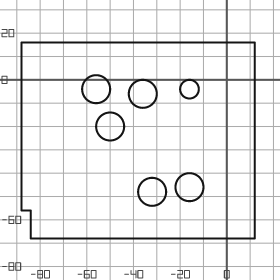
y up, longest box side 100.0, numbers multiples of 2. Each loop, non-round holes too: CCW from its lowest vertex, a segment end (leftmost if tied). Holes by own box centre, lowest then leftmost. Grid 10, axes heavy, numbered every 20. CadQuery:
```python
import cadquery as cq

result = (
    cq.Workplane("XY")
    .moveTo(-84.0, -68.0)
    .lineTo(12.0, -68.0)
    .lineTo(12.0, 16.0)
    .lineTo(-88.0, 16.0)
    .lineTo(-88.0, -56.0)
    .lineTo(-84.0, -56.0)
    .close()
    .moveTo(-32.0, -48.0)
    .circle(6.0)
    .moveTo(-16.0, -46.0)
    .circle(6.0)
    .moveTo(-50.0, -20.0)
    .circle(6.0)
    .moveTo(-36.0, -6.0)
    .circle(6.0)
    .moveTo(-56.0, -4.0)
    .circle(6.0)
    .moveTo(-16.0, -4.0)
    .circle(4.0)
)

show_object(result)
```